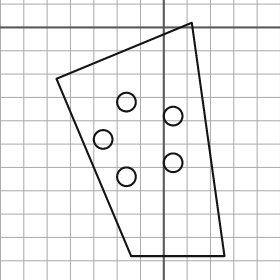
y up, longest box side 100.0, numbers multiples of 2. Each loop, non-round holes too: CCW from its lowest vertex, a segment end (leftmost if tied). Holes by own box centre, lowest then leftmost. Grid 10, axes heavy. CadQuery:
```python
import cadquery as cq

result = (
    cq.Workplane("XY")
    .moveTo(-14.0, -98.0)
    .lineTo(26.0, -98.0)
    .lineTo(12.0, 2.0)
    .lineTo(-46.0, -22.0)
    .close()
    .moveTo(-16.0, -64.0)
    .circle(4.0)
    .moveTo(4.0, -58.0)
    .circle(4.0)
    .moveTo(-26.0, -48.0)
    .circle(4.0)
    .moveTo(4.0, -38.0)
    .circle(4.0)
    .moveTo(-16.0, -32.0)
    .circle(4.0)
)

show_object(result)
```